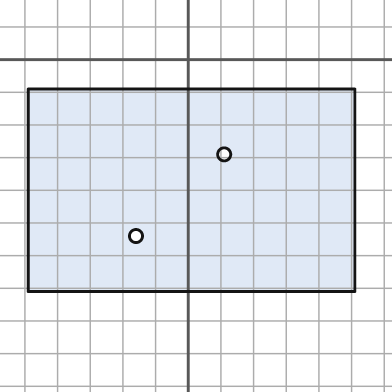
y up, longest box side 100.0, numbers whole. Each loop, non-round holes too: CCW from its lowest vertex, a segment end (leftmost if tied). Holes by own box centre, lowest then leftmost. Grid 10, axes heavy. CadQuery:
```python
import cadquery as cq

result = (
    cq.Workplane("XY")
    .moveTo(-49.0, -71.0)
    .lineTo(51.0, -71.0)
    .lineTo(51.0, -9.0)
    .lineTo(-49.0, -9.0)
    .close()
    .moveTo(-16.0, -54.0)
    .circle(2.0)
    .moveTo(11.0, -29.0)
    .circle(2.0)
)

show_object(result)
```